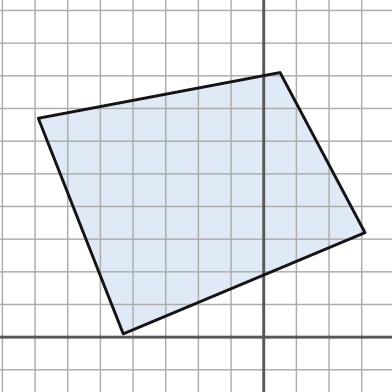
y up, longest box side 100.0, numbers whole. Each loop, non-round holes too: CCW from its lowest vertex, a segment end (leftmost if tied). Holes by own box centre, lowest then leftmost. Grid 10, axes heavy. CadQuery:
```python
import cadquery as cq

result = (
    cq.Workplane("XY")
    .moveTo(-43.0, 1.0)
    .lineTo(31.0, 32.0)
    .lineTo(5.0, 81.0)
    .lineTo(-69.0, 67.0)
    .close()
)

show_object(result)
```